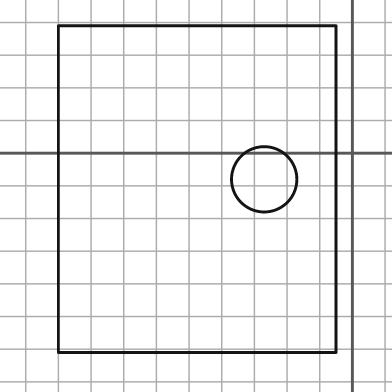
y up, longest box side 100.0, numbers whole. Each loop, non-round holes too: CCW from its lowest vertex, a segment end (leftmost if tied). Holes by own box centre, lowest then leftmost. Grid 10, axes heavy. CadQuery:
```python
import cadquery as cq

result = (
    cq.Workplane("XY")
    .moveTo(-90.0, -61.0)
    .lineTo(-5.0, -61.0)
    .lineTo(-5.0, 39.0)
    .lineTo(-90.0, 39.0)
    .close()
    .moveTo(-27.0, -8.0)
    .circle(10.0)
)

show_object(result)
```